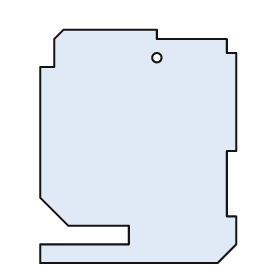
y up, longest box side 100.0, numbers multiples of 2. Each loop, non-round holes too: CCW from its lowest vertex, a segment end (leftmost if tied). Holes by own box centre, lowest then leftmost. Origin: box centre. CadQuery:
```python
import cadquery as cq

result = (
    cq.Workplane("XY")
    .moveTo(-42.0, -50.0)
    .lineTo(34.0, -50.0)
    .lineTo(42.0, -42.0)
    .lineTo(42.0, -30.0)
    .lineTo(38.0, -30.0)
    .lineTo(38.0, -2.0)
    .lineTo(42.0, -2.0)
    .lineTo(42.0, 40.0)
    .lineTo(38.0, 40.0)
    .lineTo(38.0, 46.0)
    .lineTo(8.0, 46.0)
    .lineTo(8.0, 50.0)
    .lineTo(-32.0, 50.0)
    .lineTo(-36.0, 46.0)
    .lineTo(-36.0, 34.0)
    .lineTo(-42.0, 34.0)
    .lineTo(-42.0, -22.0)
    .lineTo(-30.0, -34.0)
    .lineTo(-4.0, -34.0)
    .lineTo(-4.0, -42.0)
    .lineTo(-42.0, -42.0)
    .close()
    .moveTo(8.0, 38.0)
    .circle(2.0)
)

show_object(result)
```